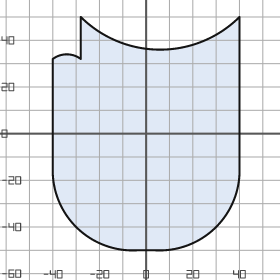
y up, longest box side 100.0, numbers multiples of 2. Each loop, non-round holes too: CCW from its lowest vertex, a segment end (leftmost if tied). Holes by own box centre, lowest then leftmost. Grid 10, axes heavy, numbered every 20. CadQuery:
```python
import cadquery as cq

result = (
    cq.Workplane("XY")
    .moveTo(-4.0, -50.0)
    .lineTo(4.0, -50.0)
    .threePointArc((30.0, -40.0), (40.0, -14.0))
    .lineTo(40.0, 50.0)
    .threePointArc((6.0, 36.0), (-28.0, 50.0))
    .lineTo(-28.0, 32.0)
    .threePointArc((-34.0, 34.0), (-40.0, 32.0))
    .lineTo(-40.0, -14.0)
    .threePointArc((-30.0, -40.0), (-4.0, -50.0))
    .close()
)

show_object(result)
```